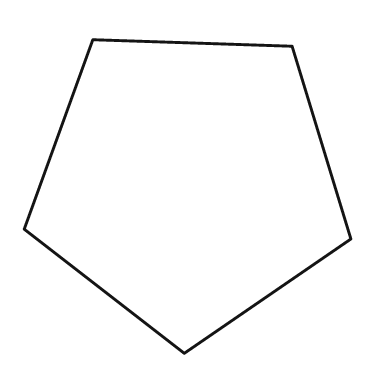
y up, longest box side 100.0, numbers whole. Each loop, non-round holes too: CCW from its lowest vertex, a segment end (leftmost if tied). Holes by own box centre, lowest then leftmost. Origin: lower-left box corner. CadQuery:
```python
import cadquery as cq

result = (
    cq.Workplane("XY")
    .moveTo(49.0, 0.0)
    .lineTo(100.0, 35.0)
    .lineTo(82.0, 94.0)
    .lineTo(21.0, 96.0)
    .lineTo(0.0, 38.0)
    .close()
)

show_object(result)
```